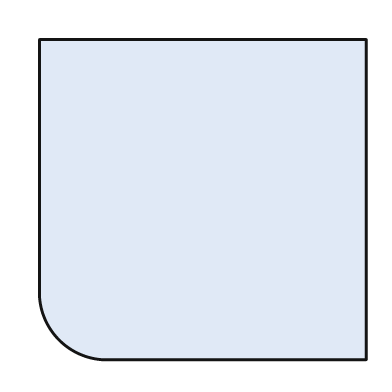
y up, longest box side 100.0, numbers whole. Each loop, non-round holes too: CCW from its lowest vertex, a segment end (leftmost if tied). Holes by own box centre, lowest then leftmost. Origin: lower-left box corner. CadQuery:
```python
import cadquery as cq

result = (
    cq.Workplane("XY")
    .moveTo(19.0, 0.0)
    .lineTo(100.0, 0.0)
    .lineTo(100.0, 98.0)
    .lineTo(0.0, 98.0)
    .lineTo(0.0, 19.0)
    .threePointArc((6.0, 6.0), (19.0, 0.0))
    .close()
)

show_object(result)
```